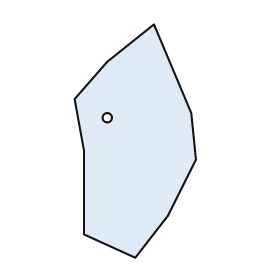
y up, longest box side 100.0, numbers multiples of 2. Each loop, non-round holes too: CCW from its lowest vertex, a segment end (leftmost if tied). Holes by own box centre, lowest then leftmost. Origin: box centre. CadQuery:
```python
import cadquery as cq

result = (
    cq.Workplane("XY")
    .moveTo(0.0, -50.0)
    .lineTo(14.0, -32.0)
    .lineTo(26.0, -8.0)
    .lineTo(24.0, 12.0)
    .lineTo(8.0, 50.0)
    .lineTo(-12.0, 34.0)
    .lineTo(-26.0, 18.0)
    .lineTo(-22.0, -4.0)
    .lineTo(-22.0, -40.0)
    .close()
    .moveTo(-12.0, 10.0)
    .circle(2.0)
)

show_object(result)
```